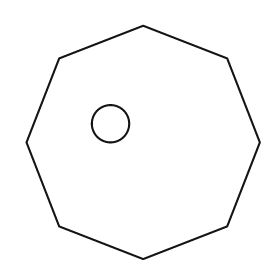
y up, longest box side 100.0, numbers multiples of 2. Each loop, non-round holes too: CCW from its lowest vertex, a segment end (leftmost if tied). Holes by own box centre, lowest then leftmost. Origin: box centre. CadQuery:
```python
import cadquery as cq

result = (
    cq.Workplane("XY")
    .moveTo(0.0, -50.0)
    .lineTo(36.0, -36.0)
    .lineTo(50.0, 0.0)
    .lineTo(36.0, 36.0)
    .lineTo(0.0, 50.0)
    .lineTo(-36.0, 36.0)
    .lineTo(-50.0, 0.0)
    .lineTo(-36.0, -36.0)
    .close()
    .moveTo(-14.0, 8.0)
    .circle(8.0)
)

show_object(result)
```